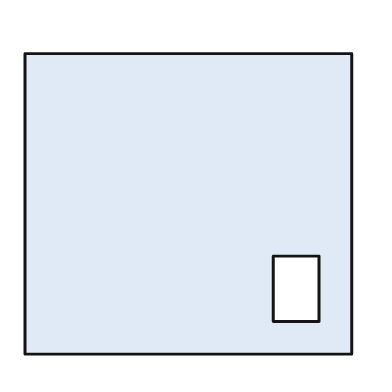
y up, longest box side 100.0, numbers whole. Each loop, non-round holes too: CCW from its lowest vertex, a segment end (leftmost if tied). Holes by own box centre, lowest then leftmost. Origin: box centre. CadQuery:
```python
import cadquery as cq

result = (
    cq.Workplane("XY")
    .moveTo(-50.0, -46.0)
    .lineTo(50.0, -46.0)
    .lineTo(50.0, 46.0)
    .lineTo(-50.0, 46.0)
    .close()
    .moveTo(26.0, -36.0)
    .lineTo(40.0, -36.0)
    .lineTo(40.0, -16.0)
    .lineTo(26.0, -16.0)
    .close()
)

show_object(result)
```